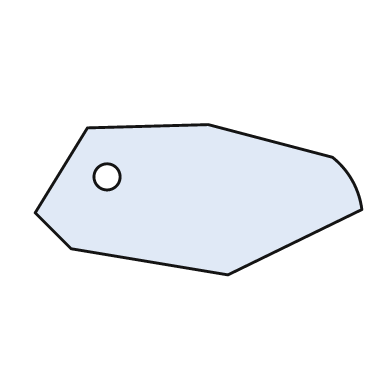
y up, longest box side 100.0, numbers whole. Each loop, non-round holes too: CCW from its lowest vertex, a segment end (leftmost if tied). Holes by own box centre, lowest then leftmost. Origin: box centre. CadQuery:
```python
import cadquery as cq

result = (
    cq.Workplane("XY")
    .moveTo(9.0, -23.0)
    .lineTo(50.0, -3.0)
    .threePointArc((47.0, 6.0), (41.0, 13.0))
    .lineTo(3.0, 23.0)
    .lineTo(-34.0, 22.0)
    .lineTo(-50.0, -4.0)
    .lineTo(-39.0, -15.0)
    .close()
    .moveTo(-28.0, 7.0)
    .circle(4.0)
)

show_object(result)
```